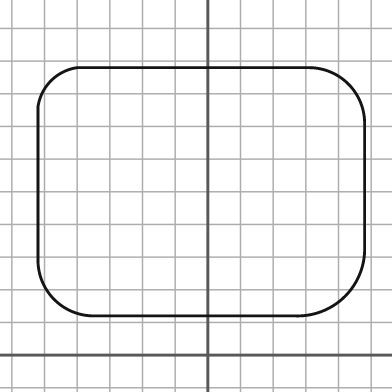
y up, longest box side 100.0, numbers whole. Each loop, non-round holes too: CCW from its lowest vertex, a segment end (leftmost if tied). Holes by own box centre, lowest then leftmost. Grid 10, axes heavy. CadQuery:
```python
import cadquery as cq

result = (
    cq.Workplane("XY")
    .moveTo(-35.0, 12.0)
    .lineTo(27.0, 12.0)
    .threePointArc((42.0, 18.0), (48.0, 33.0))
    .lineTo(48.0, 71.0)
    .threePointArc((43.0, 83.0), (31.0, 88.0))
    .lineTo(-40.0, 88.0)
    .threePointArc((-48.0, 84.0), (-52.0, 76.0))
    .lineTo(-52.0, 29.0)
    .threePointArc((-47.0, 17.0), (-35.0, 12.0))
    .close()
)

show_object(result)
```